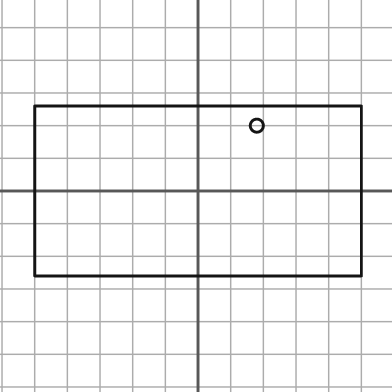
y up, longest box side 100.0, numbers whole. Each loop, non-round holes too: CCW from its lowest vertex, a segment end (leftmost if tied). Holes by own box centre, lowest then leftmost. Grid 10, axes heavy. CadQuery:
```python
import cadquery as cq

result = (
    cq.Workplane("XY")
    .moveTo(-50.0, -26.0)
    .lineTo(50.0, -26.0)
    .lineTo(50.0, 26.0)
    .lineTo(-50.0, 26.0)
    .close()
    .moveTo(18.0, 20.0)
    .circle(2.0)
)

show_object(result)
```